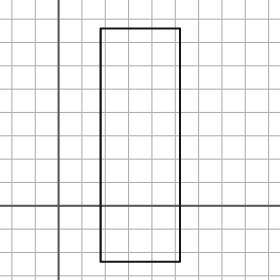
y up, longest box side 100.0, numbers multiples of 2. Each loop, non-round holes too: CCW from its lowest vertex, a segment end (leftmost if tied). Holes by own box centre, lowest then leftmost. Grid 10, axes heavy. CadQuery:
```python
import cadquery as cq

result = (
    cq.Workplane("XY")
    .moveTo(18.0, -24.0)
    .lineTo(52.0, -24.0)
    .lineTo(52.0, 76.0)
    .lineTo(18.0, 76.0)
    .close()
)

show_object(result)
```